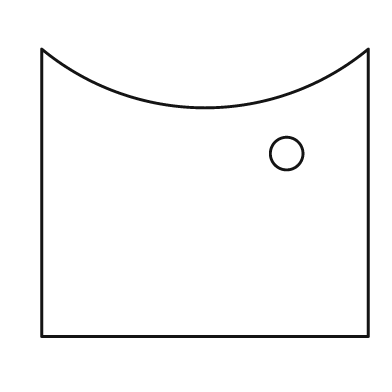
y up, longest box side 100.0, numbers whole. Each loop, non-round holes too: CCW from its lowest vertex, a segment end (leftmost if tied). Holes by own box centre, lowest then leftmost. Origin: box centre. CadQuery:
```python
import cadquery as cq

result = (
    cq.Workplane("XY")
    .moveTo(-50.0, -44.0)
    .lineTo(50.0, -44.0)
    .lineTo(50.0, 44.0)
    .threePointArc((0.0, 26.0), (-50.0, 44.0))
    .close()
    .moveTo(25.0, 12.0)
    .circle(5.0)
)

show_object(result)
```